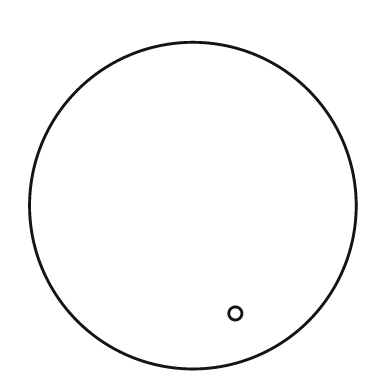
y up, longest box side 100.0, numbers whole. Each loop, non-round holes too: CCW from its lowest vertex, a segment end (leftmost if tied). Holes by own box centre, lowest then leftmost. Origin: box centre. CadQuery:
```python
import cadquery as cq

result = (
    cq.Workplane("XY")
    .moveTo(0.0, 0.0)
    .circle(50.0)
    .moveTo(13.0, -33.0)
    .circle(2.0)
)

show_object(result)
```